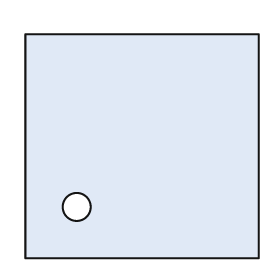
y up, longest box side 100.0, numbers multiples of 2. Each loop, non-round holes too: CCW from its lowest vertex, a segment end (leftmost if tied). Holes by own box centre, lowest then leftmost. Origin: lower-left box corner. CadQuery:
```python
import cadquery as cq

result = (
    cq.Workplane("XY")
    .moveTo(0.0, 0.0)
    .lineTo(100.0, 0.0)
    .lineTo(100.0, 96.0)
    .lineTo(0.0, 96.0)
    .close()
    .moveTo(22.0, 22.0)
    .circle(6.0)
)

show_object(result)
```